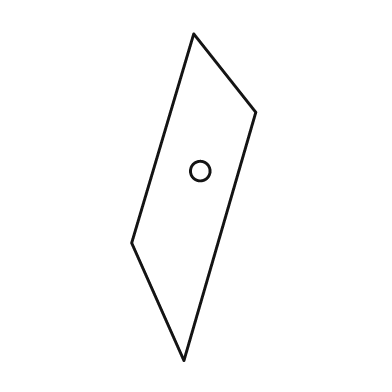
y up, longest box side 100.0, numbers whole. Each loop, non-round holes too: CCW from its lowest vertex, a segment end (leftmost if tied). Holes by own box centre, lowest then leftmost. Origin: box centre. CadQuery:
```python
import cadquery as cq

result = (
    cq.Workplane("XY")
    .moveTo(-3.0, -50.0)
    .lineTo(19.0, 26.0)
    .lineTo(0.0, 50.0)
    .lineTo(-19.0, -14.0)
    .close()
    .moveTo(2.0, 8.0)
    .circle(3.0)
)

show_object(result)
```